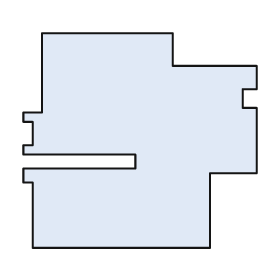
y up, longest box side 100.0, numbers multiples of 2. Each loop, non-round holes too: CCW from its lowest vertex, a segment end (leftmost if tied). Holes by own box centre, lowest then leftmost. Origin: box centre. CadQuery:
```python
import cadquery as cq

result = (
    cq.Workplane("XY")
    .moveTo(-46.0, -46.0)
    .lineTo(30.0, -46.0)
    .lineTo(30.0, -14.0)
    .lineTo(50.0, -14.0)
    .lineTo(50.0, 14.0)
    .lineTo(44.0, 14.0)
    .lineTo(44.0, 22.0)
    .lineTo(50.0, 22.0)
    .lineTo(50.0, 32.0)
    .lineTo(14.0, 32.0)
    .lineTo(14.0, 46.0)
    .lineTo(-42.0, 46.0)
    .lineTo(-42.0, 12.0)
    .lineTo(-50.0, 12.0)
    .lineTo(-50.0, 8.0)
    .lineTo(-46.0, 8.0)
    .lineTo(-46.0, -2.0)
    .lineTo(-50.0, -2.0)
    .lineTo(-50.0, -6.0)
    .lineTo(-2.0, -6.0)
    .lineTo(-2.0, -12.0)
    .lineTo(-50.0, -12.0)
    .lineTo(-50.0, -18.0)
    .lineTo(-46.0, -18.0)
    .close()
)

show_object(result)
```